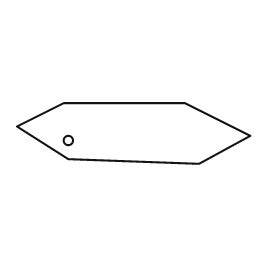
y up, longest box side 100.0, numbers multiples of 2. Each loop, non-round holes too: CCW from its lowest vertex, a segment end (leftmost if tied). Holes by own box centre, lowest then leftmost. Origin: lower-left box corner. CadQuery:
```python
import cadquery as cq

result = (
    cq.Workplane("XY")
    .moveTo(78.0, 0.0)
    .lineTo(100.0, 12.0)
    .lineTo(72.0, 26.0)
    .lineTo(20.0, 26.0)
    .lineTo(0.0, 16.0)
    .lineTo(22.0, 2.0)
    .close()
    .moveTo(22.0, 10.0)
    .circle(2.0)
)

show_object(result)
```